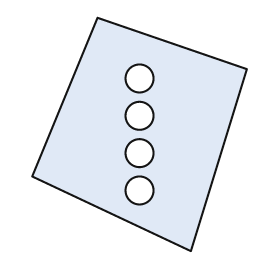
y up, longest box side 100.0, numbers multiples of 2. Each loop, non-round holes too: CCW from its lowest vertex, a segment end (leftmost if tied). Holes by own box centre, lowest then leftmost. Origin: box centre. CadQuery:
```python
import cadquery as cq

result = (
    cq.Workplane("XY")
    .moveTo(22.0, -50.0)
    .lineTo(46.0, 28.0)
    .lineTo(-18.0, 50.0)
    .lineTo(-46.0, -18.0)
    .close()
    .moveTo(0.0, -24.0)
    .circle(6.0)
    .moveTo(0.0, -8.0)
    .circle(6.0)
    .moveTo(0.0, 8.0)
    .circle(6.0)
    .moveTo(0.0, 24.0)
    .circle(6.0)
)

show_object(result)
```